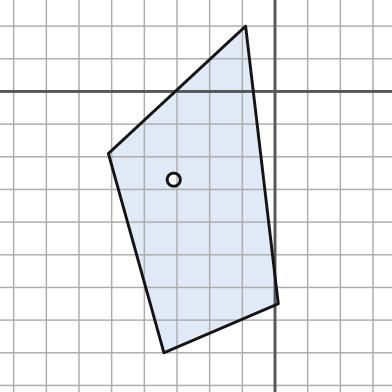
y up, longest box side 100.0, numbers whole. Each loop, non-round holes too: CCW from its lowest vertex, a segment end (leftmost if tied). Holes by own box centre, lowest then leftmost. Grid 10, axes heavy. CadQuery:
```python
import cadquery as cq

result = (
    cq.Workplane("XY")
    .moveTo(-34.0, -80.0)
    .lineTo(1.0, -65.0)
    .lineTo(-9.0, 20.0)
    .lineTo(-51.0, -19.0)
    .close()
    .moveTo(-31.0, -27.0)
    .circle(2.0)
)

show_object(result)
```